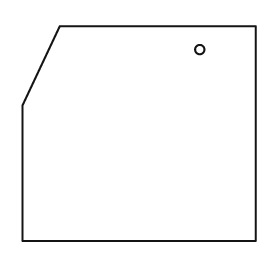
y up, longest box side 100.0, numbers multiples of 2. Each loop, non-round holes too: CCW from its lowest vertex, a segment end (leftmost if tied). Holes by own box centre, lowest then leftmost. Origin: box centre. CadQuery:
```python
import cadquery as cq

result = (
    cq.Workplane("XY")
    .moveTo(-50.0, -46.0)
    .lineTo(50.0, -46.0)
    .lineTo(50.0, 46.0)
    .lineTo(-34.0, 46.0)
    .lineTo(-50.0, 12.0)
    .close()
    .moveTo(26.0, 36.0)
    .circle(2.0)
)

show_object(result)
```